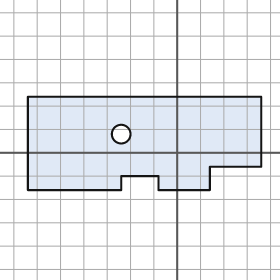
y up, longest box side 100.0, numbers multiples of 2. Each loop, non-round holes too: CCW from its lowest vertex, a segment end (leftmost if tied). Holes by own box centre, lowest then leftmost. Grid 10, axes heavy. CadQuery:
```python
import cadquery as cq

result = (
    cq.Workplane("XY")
    .moveTo(-64.0, -16.0)
    .lineTo(-24.0, -16.0)
    .lineTo(-24.0, -10.0)
    .lineTo(-8.0, -10.0)
    .lineTo(-8.0, -16.0)
    .lineTo(14.0, -16.0)
    .lineTo(14.0, -6.0)
    .lineTo(36.0, -6.0)
    .lineTo(36.0, 24.0)
    .lineTo(-64.0, 24.0)
    .close()
    .moveTo(-24.0, 8.0)
    .circle(4.0)
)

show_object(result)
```